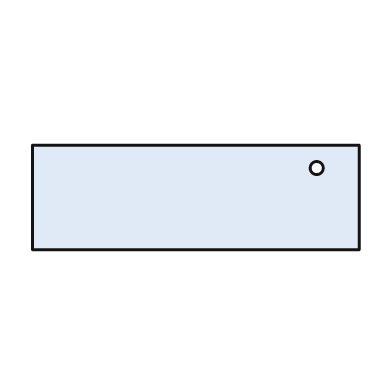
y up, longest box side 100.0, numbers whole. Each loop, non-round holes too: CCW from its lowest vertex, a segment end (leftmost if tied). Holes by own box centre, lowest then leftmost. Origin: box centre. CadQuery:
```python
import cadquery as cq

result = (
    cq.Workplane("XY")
    .moveTo(-50.0, -16.0)
    .lineTo(50.0, -16.0)
    .lineTo(50.0, 16.0)
    .lineTo(-50.0, 16.0)
    .close()
    .moveTo(37.0, 9.0)
    .circle(2.0)
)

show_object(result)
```